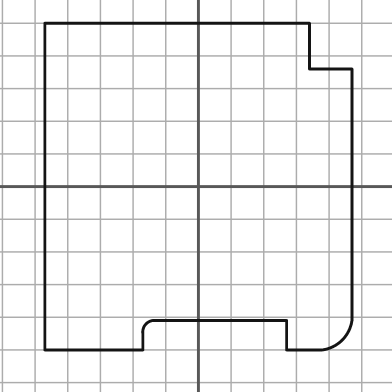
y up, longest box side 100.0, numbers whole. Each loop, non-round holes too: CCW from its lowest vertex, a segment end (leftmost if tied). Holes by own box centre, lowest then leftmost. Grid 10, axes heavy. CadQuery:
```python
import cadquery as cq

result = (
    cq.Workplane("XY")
    .moveTo(-47.0, -50.0)
    .lineTo(-17.0, -50.0)
    .lineTo(-17.0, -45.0)
    .threePointArc((-16.0, -42.0), (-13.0, -41.0))
    .lineTo(27.0, -41.0)
    .lineTo(27.0, -50.0)
    .lineTo(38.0, -50.0)
    .threePointArc((44.0, -47.0), (47.0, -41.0))
    .lineTo(47.0, 36.0)
    .lineTo(34.0, 36.0)
    .lineTo(34.0, 50.0)
    .lineTo(-47.0, 50.0)
    .close()
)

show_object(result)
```